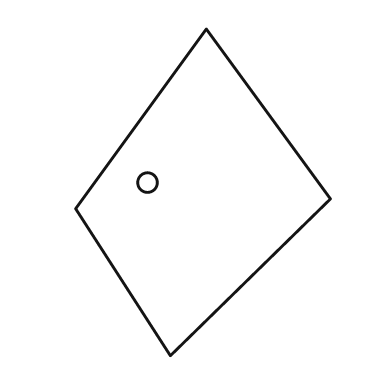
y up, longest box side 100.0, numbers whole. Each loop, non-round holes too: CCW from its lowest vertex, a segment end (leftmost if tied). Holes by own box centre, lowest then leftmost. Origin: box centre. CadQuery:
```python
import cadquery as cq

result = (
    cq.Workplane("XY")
    .moveTo(-10.0, -50.0)
    .lineTo(39.0, -2.0)
    .lineTo(1.0, 50.0)
    .lineTo(-39.0, -5.0)
    .close()
    .moveTo(-17.0, 3.0)
    .circle(3.0)
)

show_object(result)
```